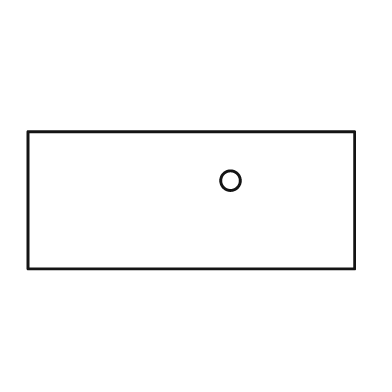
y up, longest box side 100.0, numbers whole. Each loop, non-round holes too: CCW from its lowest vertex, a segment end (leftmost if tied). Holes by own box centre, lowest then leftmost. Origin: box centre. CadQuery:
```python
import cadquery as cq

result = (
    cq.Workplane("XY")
    .moveTo(-50.0, -21.0)
    .lineTo(50.0, -21.0)
    .lineTo(50.0, 21.0)
    .lineTo(-50.0, 21.0)
    .close()
    .moveTo(12.0, 6.0)
    .circle(3.0)
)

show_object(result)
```